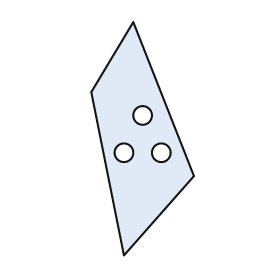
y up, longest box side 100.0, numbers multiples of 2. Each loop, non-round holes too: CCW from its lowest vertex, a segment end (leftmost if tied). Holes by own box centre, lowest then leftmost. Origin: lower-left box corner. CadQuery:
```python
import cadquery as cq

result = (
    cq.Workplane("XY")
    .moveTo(14.0, 0.0)
    .lineTo(44.0, 34.0)
    .lineTo(18.0, 100.0)
    .lineTo(0.0, 70.0)
    .close()
    .moveTo(14.0, 44.0)
    .circle(4.0)
    .moveTo(30.0, 44.0)
    .circle(4.0)
    .moveTo(22.0, 60.0)
    .circle(4.0)
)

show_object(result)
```